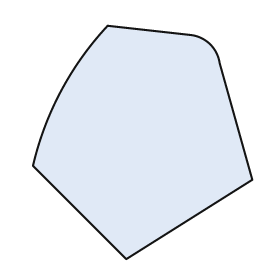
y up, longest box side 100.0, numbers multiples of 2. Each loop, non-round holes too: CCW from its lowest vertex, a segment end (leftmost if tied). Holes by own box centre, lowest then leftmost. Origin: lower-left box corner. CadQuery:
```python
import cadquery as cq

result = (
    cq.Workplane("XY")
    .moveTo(40.0, 0.0)
    .lineTo(94.0, 34.0)
    .lineTo(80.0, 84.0)
    .threePointArc((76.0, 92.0), (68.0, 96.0))
    .lineTo(32.0, 100.0)
    .threePointArc((12.0, 72.0), (0.0, 40.0))
    .close()
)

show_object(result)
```